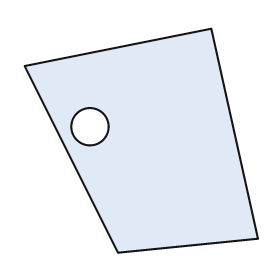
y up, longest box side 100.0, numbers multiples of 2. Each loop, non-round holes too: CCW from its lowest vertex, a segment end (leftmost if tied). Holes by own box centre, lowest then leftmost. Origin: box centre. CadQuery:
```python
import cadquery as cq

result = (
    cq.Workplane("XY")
    .moveTo(-10.0, -48.0)
    .lineTo(50.0, -42.0)
    .lineTo(30.0, 48.0)
    .lineTo(-50.0, 32.0)
    .close()
    .moveTo(-22.0, 6.0)
    .circle(8.0)
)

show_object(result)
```